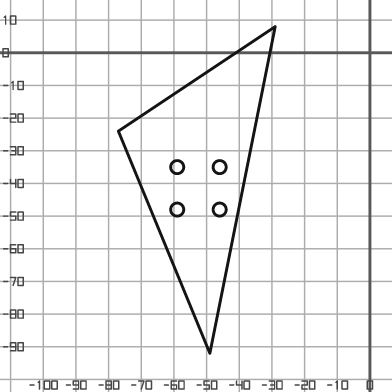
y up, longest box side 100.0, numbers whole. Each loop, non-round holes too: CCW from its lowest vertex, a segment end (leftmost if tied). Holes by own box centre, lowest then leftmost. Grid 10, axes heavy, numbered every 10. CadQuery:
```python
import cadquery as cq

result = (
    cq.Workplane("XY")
    .moveTo(-49.0, -92.0)
    .lineTo(-29.0, 8.0)
    .lineTo(-77.0, -24.0)
    .close()
    .moveTo(-59.0, -48.0)
    .circle(2.0)
    .moveTo(-46.0, -48.0)
    .circle(2.0)
    .moveTo(-59.0, -35.0)
    .circle(2.0)
    .moveTo(-46.0, -35.0)
    .circle(2.0)
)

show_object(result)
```